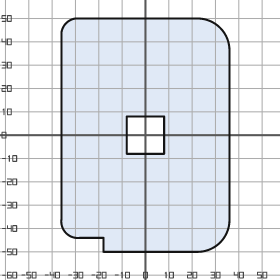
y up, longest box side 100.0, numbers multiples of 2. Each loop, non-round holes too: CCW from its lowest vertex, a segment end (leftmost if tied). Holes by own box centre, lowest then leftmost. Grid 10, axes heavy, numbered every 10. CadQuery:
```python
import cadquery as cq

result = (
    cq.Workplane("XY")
    .moveTo(-18.0, -50.0)
    .lineTo(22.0, -50.0)
    .threePointArc((32.0, -46.0), (36.0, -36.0))
    .lineTo(36.0, 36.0)
    .threePointArc((32.0, 46.0), (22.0, 50.0))
    .lineTo(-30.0, 50.0)
    .threePointArc((-34.0, 48.0), (-36.0, 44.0))
    .lineTo(-36.0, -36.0)
    .threePointArc((-34.0, -42.0), (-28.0, -44.0))
    .lineTo(-18.0, -44.0)
    .close()
    .moveTo(-8.0, -8.0)
    .lineTo(8.0, -8.0)
    .lineTo(8.0, 8.0)
    .lineTo(-8.0, 8.0)
    .close()
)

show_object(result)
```